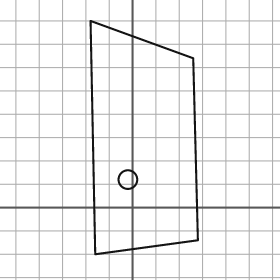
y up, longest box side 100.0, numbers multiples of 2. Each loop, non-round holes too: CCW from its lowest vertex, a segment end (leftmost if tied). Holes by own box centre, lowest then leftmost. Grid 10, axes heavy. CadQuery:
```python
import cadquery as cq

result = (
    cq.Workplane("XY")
    .moveTo(-16.0, -20.0)
    .lineTo(28.0, -14.0)
    .lineTo(26.0, 64.0)
    .lineTo(-18.0, 80.0)
    .close()
    .moveTo(-2.0, 12.0)
    .circle(4.0)
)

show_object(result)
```